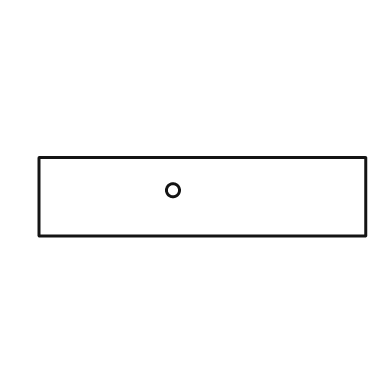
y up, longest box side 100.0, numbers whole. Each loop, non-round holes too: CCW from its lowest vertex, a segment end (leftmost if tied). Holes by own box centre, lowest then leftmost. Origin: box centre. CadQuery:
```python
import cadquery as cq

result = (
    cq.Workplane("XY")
    .moveTo(-50.0, -12.0)
    .lineTo(50.0, -12.0)
    .lineTo(50.0, 12.0)
    .lineTo(-50.0, 12.0)
    .close()
    .moveTo(-9.0, 2.0)
    .circle(2.0)
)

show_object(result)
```